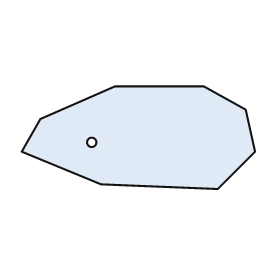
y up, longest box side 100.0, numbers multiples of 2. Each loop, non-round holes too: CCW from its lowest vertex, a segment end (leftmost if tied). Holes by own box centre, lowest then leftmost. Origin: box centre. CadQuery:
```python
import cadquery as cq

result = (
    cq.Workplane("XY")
    .moveTo(34.0, -22.0)
    .lineTo(50.0, -6.0)
    .lineTo(46.0, 12.0)
    .lineTo(28.0, 22.0)
    .lineTo(-10.0, 22.0)
    .lineTo(-42.0, 8.0)
    .lineTo(-50.0, -6.0)
    .lineTo(-16.0, -20.0)
    .close()
    .moveTo(-20.0, -2.0)
    .circle(2.0)
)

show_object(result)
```